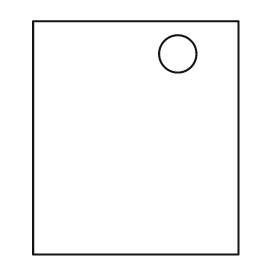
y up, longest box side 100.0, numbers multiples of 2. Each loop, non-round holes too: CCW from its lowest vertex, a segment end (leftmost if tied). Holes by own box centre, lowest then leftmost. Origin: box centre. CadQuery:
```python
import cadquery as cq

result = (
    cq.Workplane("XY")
    .moveTo(-44.0, -50.0)
    .lineTo(44.0, -50.0)
    .lineTo(44.0, 50.0)
    .lineTo(-44.0, 50.0)
    .close()
    .moveTo(18.0, 36.0)
    .circle(8.0)
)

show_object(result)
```